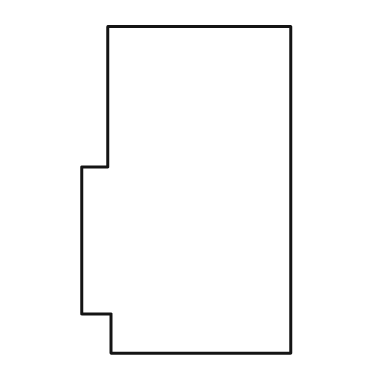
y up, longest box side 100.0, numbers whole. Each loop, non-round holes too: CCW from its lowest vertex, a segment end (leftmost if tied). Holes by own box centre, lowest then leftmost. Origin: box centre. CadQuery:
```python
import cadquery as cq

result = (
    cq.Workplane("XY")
    .moveTo(-23.0, -50.0)
    .lineTo(32.0, -50.0)
    .lineTo(32.0, 50.0)
    .lineTo(-24.0, 50.0)
    .lineTo(-24.0, 7.0)
    .lineTo(-32.0, 7.0)
    .lineTo(-32.0, -38.0)
    .lineTo(-23.0, -38.0)
    .close()
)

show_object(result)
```